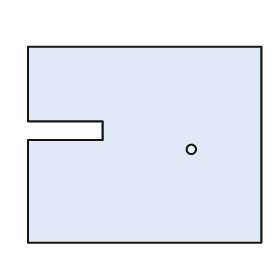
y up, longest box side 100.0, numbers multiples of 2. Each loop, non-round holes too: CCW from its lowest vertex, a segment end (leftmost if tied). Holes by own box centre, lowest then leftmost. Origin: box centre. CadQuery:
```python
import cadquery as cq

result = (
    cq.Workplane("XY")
    .moveTo(-50.0, -42.0)
    .lineTo(50.0, -42.0)
    .lineTo(50.0, 42.0)
    .lineTo(-50.0, 42.0)
    .lineTo(-50.0, 10.0)
    .lineTo(-18.0, 10.0)
    .lineTo(-18.0, 2.0)
    .lineTo(-50.0, 2.0)
    .close()
    .moveTo(20.0, -2.0)
    .circle(2.0)
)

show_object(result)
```